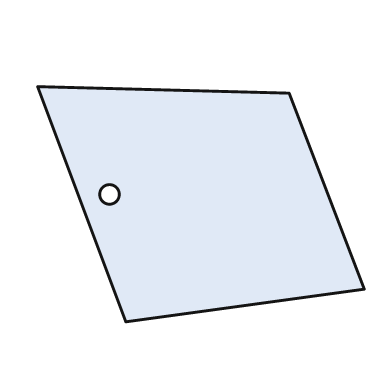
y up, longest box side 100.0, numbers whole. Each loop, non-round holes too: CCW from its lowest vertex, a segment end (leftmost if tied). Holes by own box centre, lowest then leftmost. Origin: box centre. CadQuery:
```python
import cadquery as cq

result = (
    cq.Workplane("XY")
    .moveTo(-23.0, -36.0)
    .lineTo(50.0, -26.0)
    .lineTo(27.0, 34.0)
    .lineTo(-50.0, 36.0)
    .close()
    .moveTo(-28.0, 3.0)
    .circle(3.0)
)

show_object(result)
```